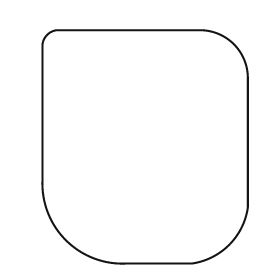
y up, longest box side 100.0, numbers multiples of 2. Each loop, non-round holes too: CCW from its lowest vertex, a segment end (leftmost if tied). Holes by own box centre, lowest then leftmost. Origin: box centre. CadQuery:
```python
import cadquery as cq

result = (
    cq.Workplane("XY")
    .moveTo(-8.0, -50.0)
    .lineTo(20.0, -50.0)
    .threePointArc((36.0, -42.0), (44.0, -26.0))
    .lineTo(44.0, 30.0)
    .threePointArc((38.0, 44.0), (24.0, 50.0))
    .lineTo(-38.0, 50.0)
    .threePointArc((-42.0, 48.0), (-44.0, 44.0))
    .lineTo(-44.0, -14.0)
    .threePointArc((-34.0, -40.0), (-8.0, -50.0))
    .close()
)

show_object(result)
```